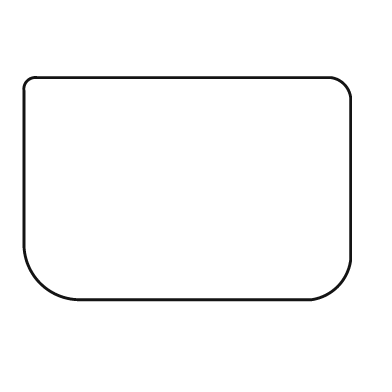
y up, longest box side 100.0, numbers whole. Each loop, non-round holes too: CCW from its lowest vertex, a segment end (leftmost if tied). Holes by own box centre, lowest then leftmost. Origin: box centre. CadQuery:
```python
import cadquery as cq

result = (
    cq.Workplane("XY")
    .moveTo(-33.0, -34.0)
    .lineTo(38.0, -34.0)
    .threePointArc((46.0, -30.0), (50.0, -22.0))
    .lineTo(50.0, 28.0)
    .threePointArc((48.0, 32.0), (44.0, 34.0))
    .lineTo(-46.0, 34.0)
    .threePointArc((-49.0, 33.0), (-50.0, 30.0))
    .lineTo(-50.0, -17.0)
    .threePointArc((-45.0, -29.0), (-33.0, -34.0))
    .close()
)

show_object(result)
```